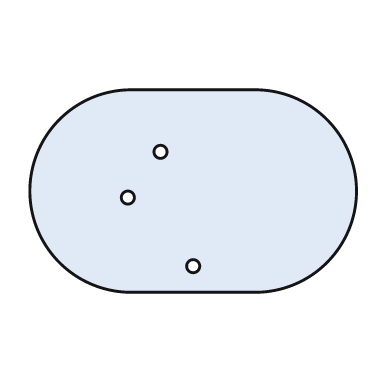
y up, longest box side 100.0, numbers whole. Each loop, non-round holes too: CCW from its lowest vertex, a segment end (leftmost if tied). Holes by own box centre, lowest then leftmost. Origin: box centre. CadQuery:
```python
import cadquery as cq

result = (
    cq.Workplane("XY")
    .moveTo(-19.0, -31.0)
    .lineTo(19.0, -31.0)
    .threePointArc((50.0, 0.0), (19.0, 31.0))
    .lineTo(-19.0, 31.0)
    .threePointArc((-50.0, 0.0), (-19.0, -31.0))
    .close()
    .moveTo(0.0, -23.0)
    .circle(2.0)
    .moveTo(-20.0, -2.0)
    .circle(2.0)
    .moveTo(-10.0, 12.0)
    .circle(2.0)
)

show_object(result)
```